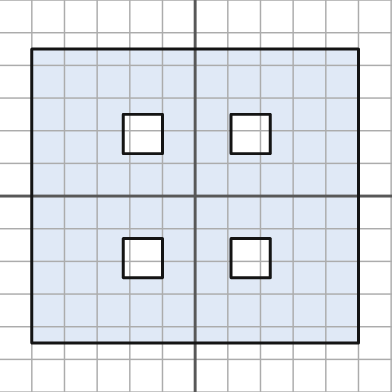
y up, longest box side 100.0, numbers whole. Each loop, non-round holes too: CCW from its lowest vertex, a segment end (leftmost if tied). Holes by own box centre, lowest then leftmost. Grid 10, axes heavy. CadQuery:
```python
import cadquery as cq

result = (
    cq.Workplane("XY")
    .moveTo(-50.0, -45.0)
    .lineTo(50.0, -45.0)
    .lineTo(50.0, 45.0)
    .lineTo(-50.0, 45.0)
    .close()
    .moveTo(-22.0, -25.0)
    .lineTo(-10.0, -25.0)
    .lineTo(-10.0, -13.0)
    .lineTo(-22.0, -13.0)
    .close()
    .moveTo(11.0, -25.0)
    .lineTo(23.0, -25.0)
    .lineTo(23.0, -13.0)
    .lineTo(11.0, -13.0)
    .close()
    .moveTo(-22.0, 13.0)
    .lineTo(-10.0, 13.0)
    .lineTo(-10.0, 25.0)
    .lineTo(-22.0, 25.0)
    .close()
    .moveTo(11.0, 13.0)
    .lineTo(23.0, 13.0)
    .lineTo(23.0, 25.0)
    .lineTo(11.0, 25.0)
    .close()
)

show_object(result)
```